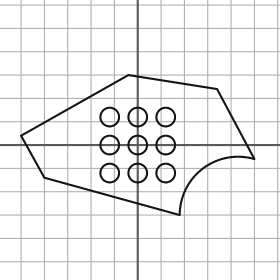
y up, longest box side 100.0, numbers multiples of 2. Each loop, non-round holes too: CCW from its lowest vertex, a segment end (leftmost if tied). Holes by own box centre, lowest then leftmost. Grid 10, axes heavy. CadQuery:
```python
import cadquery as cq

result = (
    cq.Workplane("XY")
    .moveTo(18.0, -30.0)
    .threePointArc((28.0, -10.0), (50.0, -6.0))
    .lineTo(34.0, 24.0)
    .lineTo(-4.0, 30.0)
    .lineTo(-50.0, 4.0)
    .lineTo(-40.0, -14.0)
    .close()
    .moveTo(-12.0, -12.0)
    .circle(4.0)
    .moveTo(0.0, -12.0)
    .circle(4.0)
    .moveTo(12.0, -12.0)
    .circle(4.0)
    .moveTo(-12.0, 0.0)
    .circle(4.0)
    .moveTo(0.0, 0.0)
    .circle(4.0)
    .moveTo(12.0, 0.0)
    .circle(4.0)
    .moveTo(-12.0, 12.0)
    .circle(4.0)
    .moveTo(0.0, 12.0)
    .circle(4.0)
    .moveTo(12.0, 12.0)
    .circle(4.0)
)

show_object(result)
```